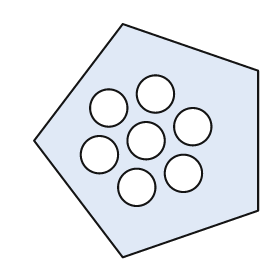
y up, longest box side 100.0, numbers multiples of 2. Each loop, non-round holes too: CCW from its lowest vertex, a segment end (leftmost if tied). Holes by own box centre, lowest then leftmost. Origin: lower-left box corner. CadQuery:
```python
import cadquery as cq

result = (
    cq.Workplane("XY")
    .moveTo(38.0, 0.0)
    .lineTo(96.0, 20.0)
    .lineTo(96.0, 80.0)
    .lineTo(38.0, 100.0)
    .lineTo(0.0, 50.0)
    .close()
    .moveTo(44.0, 30.0)
    .circle(8.0)
    .moveTo(64.0, 36.0)
    .circle(8.0)
    .moveTo(28.0, 44.0)
    .circle(8.0)
    .moveTo(48.0, 50.0)
    .circle(8.0)
    .moveTo(68.0, 56.0)
    .circle(8.0)
    .moveTo(32.0, 64.0)
    .circle(8.0)
    .moveTo(52.0, 70.0)
    .circle(8.0)
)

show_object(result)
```